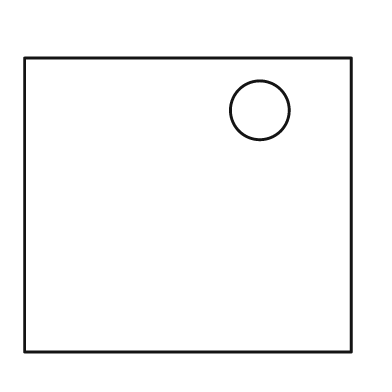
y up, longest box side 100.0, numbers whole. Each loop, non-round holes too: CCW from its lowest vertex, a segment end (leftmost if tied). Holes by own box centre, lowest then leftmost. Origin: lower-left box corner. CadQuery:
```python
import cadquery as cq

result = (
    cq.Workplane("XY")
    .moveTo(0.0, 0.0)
    .lineTo(100.0, 0.0)
    .lineTo(100.0, 90.0)
    .lineTo(0.0, 90.0)
    .close()
    .moveTo(72.0, 74.0)
    .circle(9.0)
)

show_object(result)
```